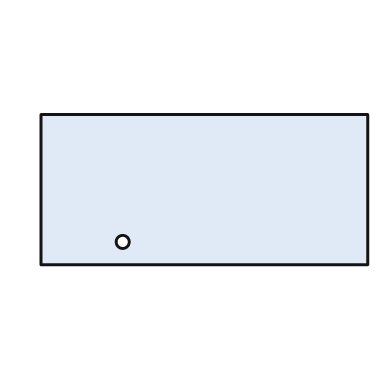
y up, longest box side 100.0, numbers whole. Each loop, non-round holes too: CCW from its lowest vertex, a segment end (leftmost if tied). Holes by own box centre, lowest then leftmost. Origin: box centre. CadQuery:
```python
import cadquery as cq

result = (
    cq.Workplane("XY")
    .moveTo(-50.0, -23.0)
    .lineTo(50.0, -23.0)
    .lineTo(50.0, 23.0)
    .lineTo(-50.0, 23.0)
    .close()
    .moveTo(-25.0, -16.0)
    .circle(2.0)
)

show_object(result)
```